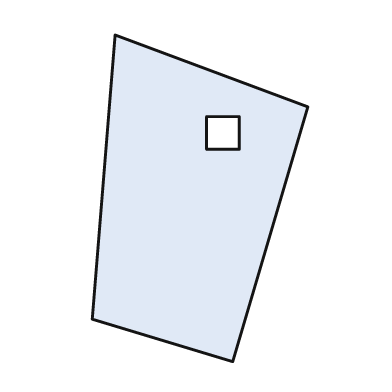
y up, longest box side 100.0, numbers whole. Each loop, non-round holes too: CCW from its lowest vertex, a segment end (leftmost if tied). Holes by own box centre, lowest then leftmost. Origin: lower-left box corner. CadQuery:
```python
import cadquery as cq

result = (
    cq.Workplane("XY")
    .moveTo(43.0, 0.0)
    .lineTo(66.0, 78.0)
    .lineTo(7.0, 100.0)
    .lineTo(0.0, 13.0)
    .close()
    .moveTo(35.0, 65.0)
    .lineTo(45.0, 65.0)
    .lineTo(45.0, 75.0)
    .lineTo(35.0, 75.0)
    .close()
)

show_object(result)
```